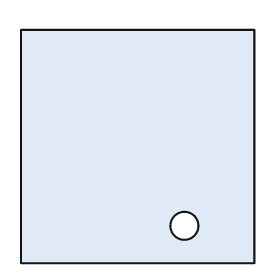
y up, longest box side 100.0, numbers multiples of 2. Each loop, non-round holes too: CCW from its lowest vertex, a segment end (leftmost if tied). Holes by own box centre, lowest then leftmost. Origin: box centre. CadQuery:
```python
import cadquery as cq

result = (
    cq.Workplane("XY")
    .moveTo(-50.0, -50.0)
    .lineTo(50.0, -50.0)
    .lineTo(50.0, 50.0)
    .lineTo(-50.0, 50.0)
    .close()
    .moveTo(20.0, -34.0)
    .circle(6.0)
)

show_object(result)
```